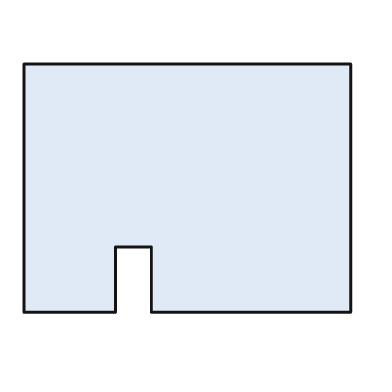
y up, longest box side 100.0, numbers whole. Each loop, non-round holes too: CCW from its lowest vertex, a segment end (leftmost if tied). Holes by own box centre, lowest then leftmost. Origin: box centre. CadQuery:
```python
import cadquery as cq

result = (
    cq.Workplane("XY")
    .moveTo(-50.0, -38.0)
    .lineTo(-22.0, -38.0)
    .lineTo(-22.0, -18.0)
    .lineTo(-11.0, -18.0)
    .lineTo(-11.0, -38.0)
    .lineTo(50.0, -38.0)
    .lineTo(50.0, 38.0)
    .lineTo(-50.0, 38.0)
    .close()
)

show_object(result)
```